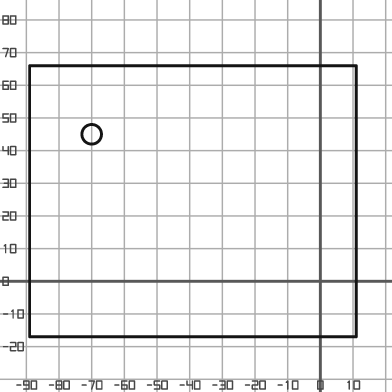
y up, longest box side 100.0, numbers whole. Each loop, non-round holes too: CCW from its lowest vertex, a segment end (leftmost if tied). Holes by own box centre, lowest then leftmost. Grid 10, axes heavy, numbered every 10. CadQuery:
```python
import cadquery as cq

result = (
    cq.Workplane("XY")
    .moveTo(-89.0, -17.0)
    .lineTo(11.0, -17.0)
    .lineTo(11.0, 66.0)
    .lineTo(-89.0, 66.0)
    .close()
    .moveTo(-70.0, 45.0)
    .circle(3.0)
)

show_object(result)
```